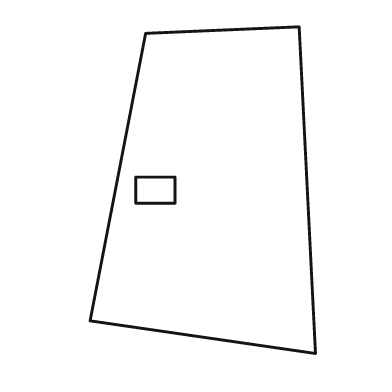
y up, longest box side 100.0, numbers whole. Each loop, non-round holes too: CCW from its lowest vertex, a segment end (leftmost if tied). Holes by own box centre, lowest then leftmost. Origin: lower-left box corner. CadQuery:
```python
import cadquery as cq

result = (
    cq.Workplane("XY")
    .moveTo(69.0, 0.0)
    .lineTo(64.0, 100.0)
    .lineTo(17.0, 98.0)
    .lineTo(0.0, 10.0)
    .close()
    .moveTo(14.0, 46.0)
    .lineTo(26.0, 46.0)
    .lineTo(26.0, 54.0)
    .lineTo(14.0, 54.0)
    .close()
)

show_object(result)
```